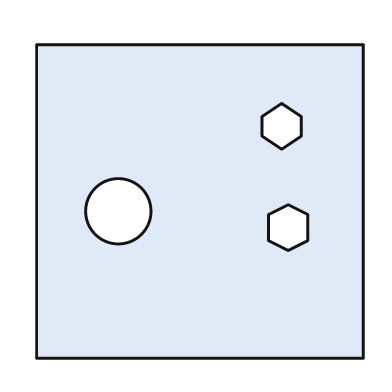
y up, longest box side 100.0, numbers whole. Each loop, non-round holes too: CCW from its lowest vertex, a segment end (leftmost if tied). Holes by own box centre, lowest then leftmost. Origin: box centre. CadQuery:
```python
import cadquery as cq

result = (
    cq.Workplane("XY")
    .moveTo(-50.0, -48.0)
    .lineTo(50.0, -48.0)
    .lineTo(50.0, 48.0)
    .lineTo(-50.0, 48.0)
    .close()
    .moveTo(27.0, -15.0)
    .lineTo(33.0, -12.0)
    .lineTo(33.0, -4.0)
    .lineTo(27.0, -1.0)
    .lineTo(21.0, -4.0)
    .lineTo(21.0, -12.0)
    .close()
    .moveTo(-25.0, -3.0)
    .circle(10.0)
    .moveTo(25.0, 16.0)
    .lineTo(31.0, 20.0)
    .lineTo(31.0, 26.0)
    .lineTo(25.0, 30.0)
    .lineTo(19.0, 26.0)
    .lineTo(19.0, 20.0)
    .close()
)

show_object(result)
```